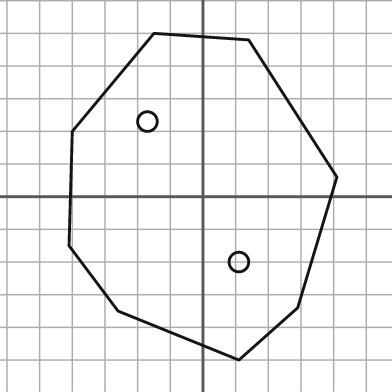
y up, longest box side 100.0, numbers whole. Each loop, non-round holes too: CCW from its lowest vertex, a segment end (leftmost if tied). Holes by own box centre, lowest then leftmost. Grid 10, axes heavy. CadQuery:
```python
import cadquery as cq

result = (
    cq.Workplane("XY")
    .moveTo(11.0, -50.0)
    .lineTo(29.0, -34.0)
    .lineTo(41.0, 6.0)
    .lineTo(14.0, 48.0)
    .lineTo(-15.0, 50.0)
    .lineTo(-40.0, 20.0)
    .lineTo(-41.0, -15.0)
    .lineTo(-26.0, -35.0)
    .close()
    .moveTo(11.0, -20.0)
    .circle(3.0)
    .moveTo(-17.0, 23.0)
    .circle(3.0)
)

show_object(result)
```